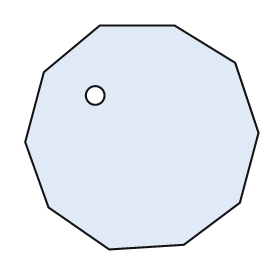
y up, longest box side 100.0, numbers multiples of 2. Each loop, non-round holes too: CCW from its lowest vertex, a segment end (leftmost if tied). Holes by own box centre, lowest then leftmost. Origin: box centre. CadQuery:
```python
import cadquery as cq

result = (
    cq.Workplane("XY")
    .moveTo(-14.0, -48.0)
    .lineTo(18.0, -46.0)
    .lineTo(42.0, -28.0)
    .lineTo(50.0, 2.0)
    .lineTo(40.0, 32.0)
    .lineTo(14.0, 48.0)
    .lineTo(-18.0, 48.0)
    .lineTo(-42.0, 28.0)
    .lineTo(-50.0, -2.0)
    .lineTo(-40.0, -30.0)
    .close()
    .moveTo(-20.0, 18.0)
    .circle(4.0)
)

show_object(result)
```